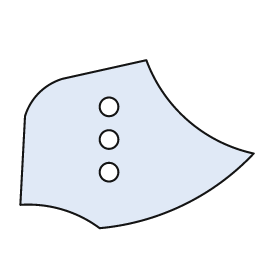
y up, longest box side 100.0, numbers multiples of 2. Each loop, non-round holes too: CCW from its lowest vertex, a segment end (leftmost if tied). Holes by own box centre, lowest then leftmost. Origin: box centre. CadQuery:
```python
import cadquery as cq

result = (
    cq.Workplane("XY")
    .moveTo(-16.0, -36.0)
    .threePointArc((20.0, -26.0), (50.0, -4.0))
    .threePointArc((22.0, 10.0), (4.0, 36.0))
    .lineTo(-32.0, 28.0)
    .threePointArc((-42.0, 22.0), (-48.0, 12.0))
    .lineTo(-50.0, -26.0)
    .threePointArc((-32.0, -28.0), (-16.0, -36.0))
    .close()
    .moveTo(-12.0, -12.0)
    .circle(4.0)
    .moveTo(-12.0, 2.0)
    .circle(4.0)
    .moveTo(-12.0, 16.0)
    .circle(4.0)
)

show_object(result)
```